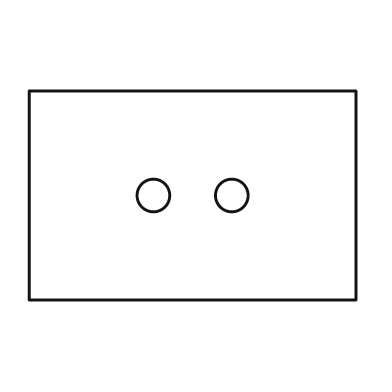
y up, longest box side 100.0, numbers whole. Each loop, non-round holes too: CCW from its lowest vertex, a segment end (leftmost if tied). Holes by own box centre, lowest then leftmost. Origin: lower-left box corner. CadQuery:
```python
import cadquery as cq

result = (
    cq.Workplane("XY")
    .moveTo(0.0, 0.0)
    .lineTo(100.0, 0.0)
    .lineTo(100.0, 64.0)
    .lineTo(0.0, 64.0)
    .close()
    .moveTo(38.0, 32.0)
    .circle(5.0)
    .moveTo(62.0, 32.0)
    .circle(5.0)
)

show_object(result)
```